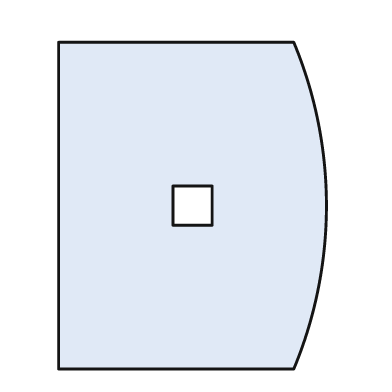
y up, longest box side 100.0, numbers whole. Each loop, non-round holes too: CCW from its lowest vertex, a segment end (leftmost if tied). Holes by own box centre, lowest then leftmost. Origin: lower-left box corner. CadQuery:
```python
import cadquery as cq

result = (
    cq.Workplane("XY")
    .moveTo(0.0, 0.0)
    .lineTo(72.0, 0.0)
    .threePointArc((82.0, 50.0), (72.0, 100.0))
    .lineTo(0.0, 100.0)
    .close()
    .moveTo(35.0, 44.0)
    .lineTo(47.0, 44.0)
    .lineTo(47.0, 56.0)
    .lineTo(35.0, 56.0)
    .close()
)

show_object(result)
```